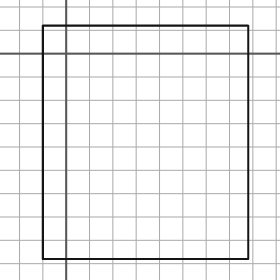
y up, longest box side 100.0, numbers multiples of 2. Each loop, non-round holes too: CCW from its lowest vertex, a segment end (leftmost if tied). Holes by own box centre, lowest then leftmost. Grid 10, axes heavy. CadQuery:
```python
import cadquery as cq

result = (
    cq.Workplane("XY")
    .moveTo(-10.0, -88.0)
    .lineTo(78.0, -88.0)
    .lineTo(78.0, 12.0)
    .lineTo(-10.0, 12.0)
    .close()
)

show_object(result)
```